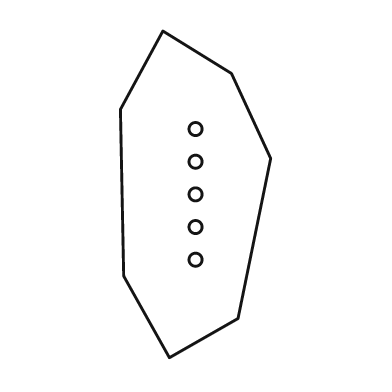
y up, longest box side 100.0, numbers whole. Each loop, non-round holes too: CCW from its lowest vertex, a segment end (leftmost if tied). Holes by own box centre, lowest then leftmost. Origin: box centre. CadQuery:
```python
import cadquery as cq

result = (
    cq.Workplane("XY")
    .moveTo(-8.0, -50.0)
    .lineTo(13.0, -38.0)
    .lineTo(23.0, 11.0)
    .lineTo(11.0, 37.0)
    .lineTo(-10.0, 50.0)
    .lineTo(-23.0, 26.0)
    .lineTo(-22.0, -25.0)
    .close()
    .moveTo(0.0, -20.0)
    .circle(2.0)
    .moveTo(0.0, -10.0)
    .circle(2.0)
    .moveTo(0.0, 0.0)
    .circle(2.0)
    .moveTo(0.0, 10.0)
    .circle(2.0)
    .moveTo(0.0, 20.0)
    .circle(2.0)
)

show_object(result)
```